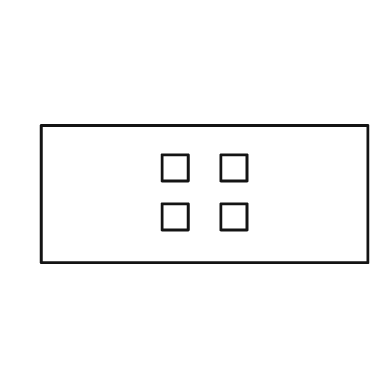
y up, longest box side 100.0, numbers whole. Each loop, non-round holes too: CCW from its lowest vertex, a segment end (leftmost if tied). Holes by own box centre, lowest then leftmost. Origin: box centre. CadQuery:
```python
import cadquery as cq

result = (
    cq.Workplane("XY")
    .moveTo(-50.0, -21.0)
    .lineTo(50.0, -21.0)
    .lineTo(50.0, 21.0)
    .lineTo(-50.0, 21.0)
    .close()
    .moveTo(-13.0, -11.0)
    .lineTo(-5.0, -11.0)
    .lineTo(-5.0, -3.0)
    .lineTo(-13.0, -3.0)
    .close()
    .moveTo(5.0, -11.0)
    .lineTo(13.0, -11.0)
    .lineTo(13.0, -3.0)
    .lineTo(5.0, -3.0)
    .close()
    .moveTo(-13.0, 4.0)
    .lineTo(-5.0, 4.0)
    .lineTo(-5.0, 12.0)
    .lineTo(-13.0, 12.0)
    .close()
    .moveTo(5.0, 4.0)
    .lineTo(13.0, 4.0)
    .lineTo(13.0, 12.0)
    .lineTo(5.0, 12.0)
    .close()
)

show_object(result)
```